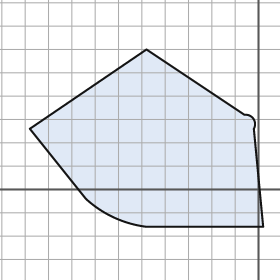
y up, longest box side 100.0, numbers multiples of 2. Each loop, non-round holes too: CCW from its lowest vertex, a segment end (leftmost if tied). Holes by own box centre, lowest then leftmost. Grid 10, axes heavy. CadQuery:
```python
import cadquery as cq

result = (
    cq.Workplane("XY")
    .moveTo(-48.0, -16.0)
    .lineTo(2.0, -16.0)
    .lineTo(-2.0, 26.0)
    .threePointArc((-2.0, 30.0), (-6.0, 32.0))
    .lineTo(-48.0, 60.0)
    .lineTo(-98.0, 26.0)
    .lineTo(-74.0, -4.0)
    .threePointArc((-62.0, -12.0), (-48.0, -16.0))
    .close()
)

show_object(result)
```